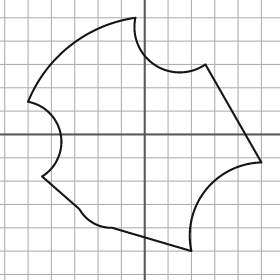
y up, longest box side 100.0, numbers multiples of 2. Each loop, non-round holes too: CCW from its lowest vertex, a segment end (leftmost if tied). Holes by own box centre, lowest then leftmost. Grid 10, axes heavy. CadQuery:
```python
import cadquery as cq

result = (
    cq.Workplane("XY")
    .moveTo(20.0, -50.0)
    .threePointArc((26.0, -24.0), (50.0, -12.0))
    .lineTo(26.0, 30.0)
    .threePointArc((4.0, 30.0), (-4.0, 50.0))
    .threePointArc((-32.0, 38.0), (-50.0, 14.0))
    .threePointArc((-36.0, 0.0), (-44.0, -18.0))
    .lineTo(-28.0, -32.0)
    .threePointArc((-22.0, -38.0), (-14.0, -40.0))
    .close()
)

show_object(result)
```